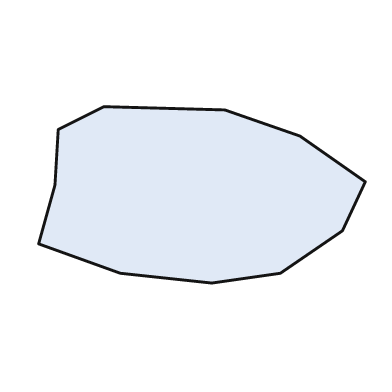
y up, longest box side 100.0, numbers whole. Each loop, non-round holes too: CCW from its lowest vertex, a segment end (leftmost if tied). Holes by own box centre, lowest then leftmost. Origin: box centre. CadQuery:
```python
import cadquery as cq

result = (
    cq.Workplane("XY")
    .moveTo(3.0, -27.0)
    .lineTo(24.0, -24.0)
    .lineTo(43.0, -11.0)
    .lineTo(50.0, 4.0)
    .lineTo(30.0, 18.0)
    .lineTo(7.0, 26.0)
    .lineTo(-30.0, 27.0)
    .lineTo(-44.0, 20.0)
    .lineTo(-45.0, 3.0)
    .lineTo(-50.0, -15.0)
    .lineTo(-25.0, -24.0)
    .close()
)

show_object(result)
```